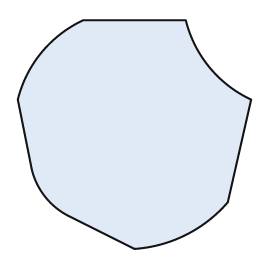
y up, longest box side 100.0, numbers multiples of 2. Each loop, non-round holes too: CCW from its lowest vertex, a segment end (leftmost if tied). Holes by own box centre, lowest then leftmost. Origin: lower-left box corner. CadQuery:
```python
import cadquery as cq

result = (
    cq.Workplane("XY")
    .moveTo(50.0, 0.0)
    .threePointArc((72.0, 6.0), (90.0, 20.0))
    .lineTo(100.0, 64.0)
    .threePointArc((82.0, 78.0), (72.0, 98.0))
    .lineTo(28.0, 98.0)
    .threePointArc((10.0, 84.0), (0.0, 64.0))
    .lineTo(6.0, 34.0)
    .threePointArc((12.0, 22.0), (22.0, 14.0))
    .close()
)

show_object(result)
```